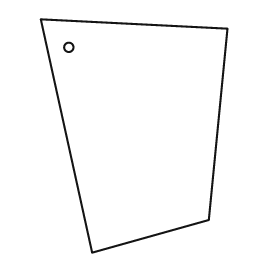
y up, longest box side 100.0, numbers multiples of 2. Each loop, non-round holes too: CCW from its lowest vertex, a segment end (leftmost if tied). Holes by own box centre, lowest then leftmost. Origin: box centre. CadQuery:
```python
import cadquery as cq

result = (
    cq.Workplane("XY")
    .moveTo(-18.0, -50.0)
    .lineTo(32.0, -36.0)
    .lineTo(40.0, 46.0)
    .lineTo(-40.0, 50.0)
    .close()
    .moveTo(-28.0, 38.0)
    .circle(2.0)
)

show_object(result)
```